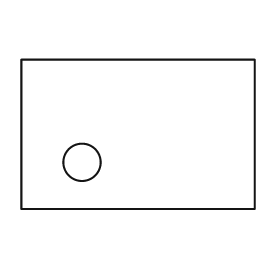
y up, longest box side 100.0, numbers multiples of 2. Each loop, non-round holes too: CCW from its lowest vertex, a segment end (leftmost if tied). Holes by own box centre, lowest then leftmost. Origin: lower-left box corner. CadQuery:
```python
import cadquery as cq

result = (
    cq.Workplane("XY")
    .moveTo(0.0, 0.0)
    .lineTo(100.0, 0.0)
    .lineTo(100.0, 64.0)
    .lineTo(0.0, 64.0)
    .close()
    .moveTo(26.0, 20.0)
    .circle(8.0)
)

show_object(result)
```